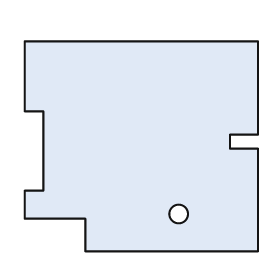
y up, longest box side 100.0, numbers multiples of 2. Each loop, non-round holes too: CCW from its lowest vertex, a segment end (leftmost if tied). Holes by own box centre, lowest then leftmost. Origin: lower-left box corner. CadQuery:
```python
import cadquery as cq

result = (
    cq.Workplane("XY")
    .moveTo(26.0, 0.0)
    .lineTo(100.0, 0.0)
    .lineTo(100.0, 44.0)
    .lineTo(88.0, 44.0)
    .lineTo(88.0, 50.0)
    .lineTo(100.0, 50.0)
    .lineTo(100.0, 90.0)
    .lineTo(0.0, 90.0)
    .lineTo(0.0, 60.0)
    .lineTo(8.0, 60.0)
    .lineTo(8.0, 26.0)
    .lineTo(0.0, 26.0)
    .lineTo(0.0, 14.0)
    .lineTo(26.0, 14.0)
    .close()
    .moveTo(66.0, 16.0)
    .circle(4.0)
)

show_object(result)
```